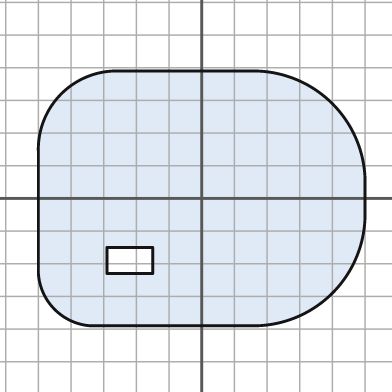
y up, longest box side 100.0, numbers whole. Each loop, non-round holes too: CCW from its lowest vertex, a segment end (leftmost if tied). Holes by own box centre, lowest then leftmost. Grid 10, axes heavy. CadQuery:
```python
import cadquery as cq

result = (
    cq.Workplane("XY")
    .moveTo(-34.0, -39.0)
    .lineTo(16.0, -39.0)
    .threePointArc((40.0, -29.0), (50.0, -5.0))
    .lineTo(50.0, 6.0)
    .threePointArc((40.0, 29.0), (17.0, 39.0))
    .lineTo(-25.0, 39.0)
    .threePointArc((-43.0, 32.0), (-50.0, 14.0))
    .lineTo(-50.0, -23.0)
    .threePointArc((-45.0, -34.0), (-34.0, -39.0))
    .close()
    .moveTo(-29.0, -23.0)
    .lineTo(-15.0, -23.0)
    .lineTo(-15.0, -15.0)
    .lineTo(-29.0, -15.0)
    .close()
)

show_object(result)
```